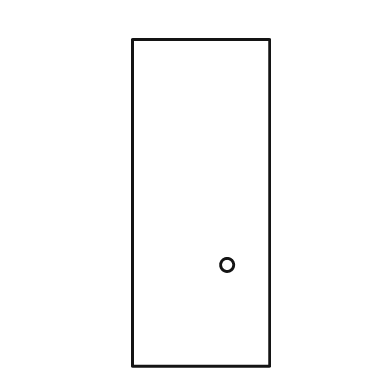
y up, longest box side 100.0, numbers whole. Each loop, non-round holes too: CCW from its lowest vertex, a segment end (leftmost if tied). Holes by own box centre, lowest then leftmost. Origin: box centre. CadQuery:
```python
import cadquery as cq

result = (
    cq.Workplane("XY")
    .moveTo(-21.0, -50.0)
    .lineTo(21.0, -50.0)
    .lineTo(21.0, 50.0)
    .lineTo(-21.0, 50.0)
    .close()
    .moveTo(8.0, -19.0)
    .circle(2.0)
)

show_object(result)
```